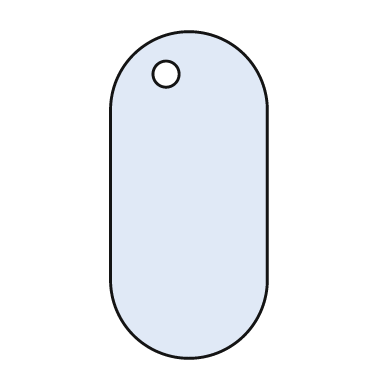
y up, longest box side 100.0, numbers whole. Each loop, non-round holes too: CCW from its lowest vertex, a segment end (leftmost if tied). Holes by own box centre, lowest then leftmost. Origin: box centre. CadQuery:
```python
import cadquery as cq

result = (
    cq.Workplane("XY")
    .moveTo(-24.0, -26.0)
    .threePointArc((0.0, -50.0), (24.0, -26.0))
    .lineTo(24.0, 26.0)
    .threePointArc((0.0, 50.0), (-24.0, 26.0))
    .close()
    .moveTo(-7.0, 37.0)
    .circle(4.0)
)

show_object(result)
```